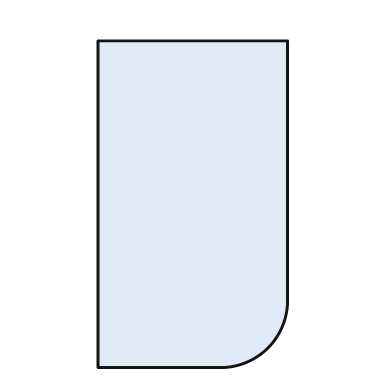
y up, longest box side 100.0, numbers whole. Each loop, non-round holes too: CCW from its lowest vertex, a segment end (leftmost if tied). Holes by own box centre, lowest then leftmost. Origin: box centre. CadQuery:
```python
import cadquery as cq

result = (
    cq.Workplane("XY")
    .moveTo(-29.0, -50.0)
    .lineTo(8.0, -50.0)
    .threePointArc((23.0, -44.0), (29.0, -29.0))
    .lineTo(29.0, 50.0)
    .lineTo(-29.0, 50.0)
    .close()
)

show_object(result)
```